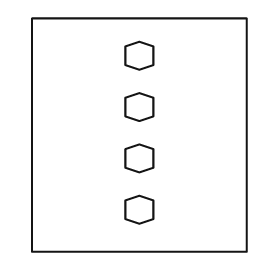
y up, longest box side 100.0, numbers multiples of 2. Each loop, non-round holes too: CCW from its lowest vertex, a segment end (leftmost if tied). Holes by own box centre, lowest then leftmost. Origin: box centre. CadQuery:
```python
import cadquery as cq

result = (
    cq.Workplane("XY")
    .moveTo(-46.0, -50.0)
    .lineTo(46.0, -50.0)
    .lineTo(46.0, 50.0)
    .lineTo(-46.0, 50.0)
    .close()
    .moveTo(0.0, -38.0)
    .lineTo(6.0, -36.0)
    .lineTo(6.0, -28.0)
    .lineTo(0.0, -26.0)
    .lineTo(-6.0, -28.0)
    .lineTo(-6.0, -36.0)
    .close()
    .moveTo(0.0, -16.0)
    .lineTo(6.0, -14.0)
    .lineTo(6.0, -6.0)
    .lineTo(0.0, -4.0)
    .lineTo(-6.0, -6.0)
    .lineTo(-6.0, -14.0)
    .close()
    .moveTo(0.0, 6.0)
    .lineTo(6.0, 8.0)
    .lineTo(6.0, 16.0)
    .lineTo(0.0, 18.0)
    .lineTo(-6.0, 16.0)
    .lineTo(-6.0, 8.0)
    .close()
    .moveTo(0.0, 28.0)
    .lineTo(6.0, 30.0)
    .lineTo(6.0, 38.0)
    .lineTo(0.0, 40.0)
    .lineTo(-6.0, 38.0)
    .lineTo(-6.0, 30.0)
    .close()
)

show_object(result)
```